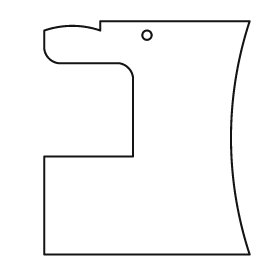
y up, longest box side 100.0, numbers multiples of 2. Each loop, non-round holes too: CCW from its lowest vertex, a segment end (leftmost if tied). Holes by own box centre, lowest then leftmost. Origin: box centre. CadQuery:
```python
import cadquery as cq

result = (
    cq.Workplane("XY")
    .moveTo(-44.0, -50.0)
    .lineTo(44.0, -50.0)
    .threePointArc((36.0, 0.0), (44.0, 50.0))
    .lineTo(-20.0, 50.0)
    .lineTo(-20.0, 46.0)
    .threePointArc((-32.0, 48.0), (-44.0, 46.0))
    .lineTo(-44.0, 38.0)
    .threePointArc((-42.0, 34.0), (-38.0, 32.0))
    .lineTo(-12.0, 32.0)
    .threePointArc((-8.0, 30.0), (-6.0, 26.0))
    .lineTo(-6.0, -8.0)
    .lineTo(-44.0, -8.0)
    .close()
    .moveTo(0.0, 44.0)
    .circle(2.0)
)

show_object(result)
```